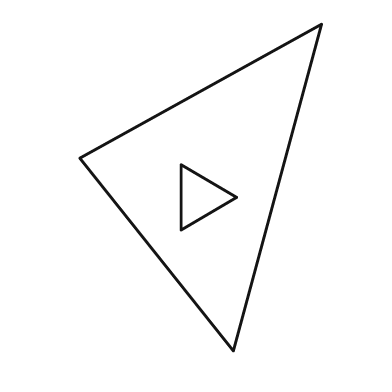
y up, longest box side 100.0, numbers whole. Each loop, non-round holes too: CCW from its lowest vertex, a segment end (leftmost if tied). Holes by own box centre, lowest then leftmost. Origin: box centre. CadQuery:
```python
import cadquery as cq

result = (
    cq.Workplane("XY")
    .moveTo(10.0, -50.0)
    .lineTo(37.0, 50.0)
    .lineTo(-37.0, 9.0)
    .close()
    .moveTo(-6.0, -13.0)
    .lineTo(11.0, -3.0)
    .lineTo(-6.0, 7.0)
    .close()
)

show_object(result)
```